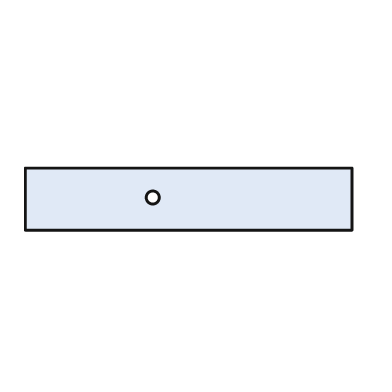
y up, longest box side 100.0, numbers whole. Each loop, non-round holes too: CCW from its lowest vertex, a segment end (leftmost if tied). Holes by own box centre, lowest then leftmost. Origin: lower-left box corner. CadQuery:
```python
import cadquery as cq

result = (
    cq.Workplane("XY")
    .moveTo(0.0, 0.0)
    .lineTo(100.0, 0.0)
    .lineTo(100.0, 19.0)
    .lineTo(0.0, 19.0)
    .close()
    .moveTo(39.0, 10.0)
    .circle(2.0)
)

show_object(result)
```